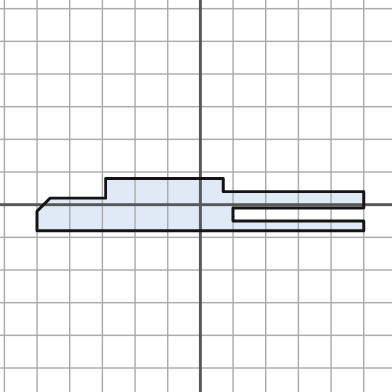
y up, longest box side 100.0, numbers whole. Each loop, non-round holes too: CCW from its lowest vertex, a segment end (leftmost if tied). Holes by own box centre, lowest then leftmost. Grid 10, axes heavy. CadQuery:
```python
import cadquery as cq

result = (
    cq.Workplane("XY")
    .moveTo(-50.0, -8.0)
    .lineTo(50.0, -8.0)
    .lineTo(50.0, -5.0)
    .lineTo(10.0, -5.0)
    .lineTo(10.0, -1.0)
    .lineTo(50.0, -1.0)
    .lineTo(50.0, 4.0)
    .lineTo(7.0, 4.0)
    .lineTo(7.0, 8.0)
    .lineTo(-29.0, 8.0)
    .lineTo(-29.0, 2.0)
    .lineTo(-46.0, 2.0)
    .lineTo(-50.0, -2.0)
    .close()
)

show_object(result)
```